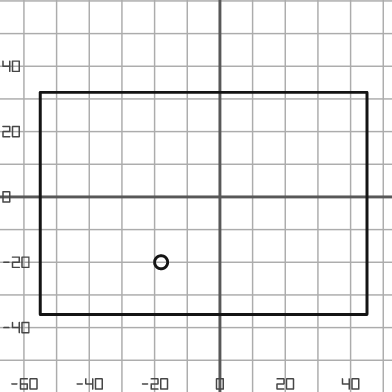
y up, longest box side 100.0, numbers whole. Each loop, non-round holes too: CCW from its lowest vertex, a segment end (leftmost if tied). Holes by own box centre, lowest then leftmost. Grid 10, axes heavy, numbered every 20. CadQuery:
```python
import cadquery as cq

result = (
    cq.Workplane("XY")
    .moveTo(-55.0, -36.0)
    .lineTo(45.0, -36.0)
    .lineTo(45.0, 32.0)
    .lineTo(-55.0, 32.0)
    .close()
    .moveTo(-18.0, -20.0)
    .circle(2.0)
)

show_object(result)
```